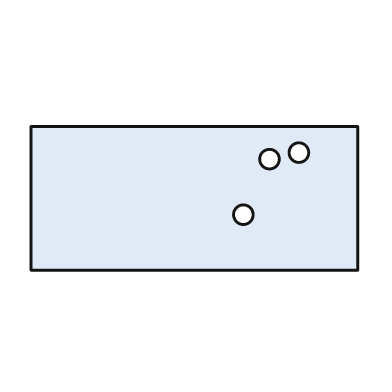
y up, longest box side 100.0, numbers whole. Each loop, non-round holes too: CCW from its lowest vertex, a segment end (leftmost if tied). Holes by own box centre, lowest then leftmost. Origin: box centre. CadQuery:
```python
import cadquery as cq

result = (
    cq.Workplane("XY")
    .moveTo(-50.0, -22.0)
    .lineTo(50.0, -22.0)
    .lineTo(50.0, 22.0)
    .lineTo(-50.0, 22.0)
    .close()
    .moveTo(15.0, -5.0)
    .circle(3.0)
    .moveTo(23.0, 12.0)
    .circle(3.0)
    .moveTo(32.0, 14.0)
    .circle(3.0)
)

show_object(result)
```